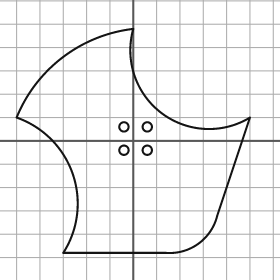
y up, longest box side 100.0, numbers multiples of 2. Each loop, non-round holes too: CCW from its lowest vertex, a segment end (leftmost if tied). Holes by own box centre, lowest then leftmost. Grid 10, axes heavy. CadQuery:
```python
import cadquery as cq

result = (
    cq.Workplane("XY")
    .moveTo(-30.0, -48.0)
    .lineTo(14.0, -48.0)
    .threePointArc((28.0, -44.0), (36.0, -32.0))
    .lineTo(50.0, 10.0)
    .threePointArc((12.0, 12.0), (0.0, 48.0))
    .threePointArc((-30.0, 36.0), (-50.0, 10.0))
    .threePointArc((-26.0, -14.0), (-30.0, -48.0))
    .close()
    .moveTo(-4.0, -4.0)
    .circle(2.0)
    .moveTo(6.0, -4.0)
    .circle(2.0)
    .moveTo(-4.0, 6.0)
    .circle(2.0)
    .moveTo(6.0, 6.0)
    .circle(2.0)
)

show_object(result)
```